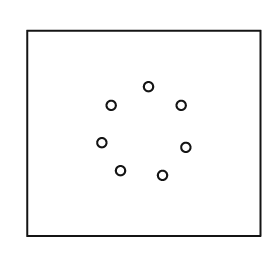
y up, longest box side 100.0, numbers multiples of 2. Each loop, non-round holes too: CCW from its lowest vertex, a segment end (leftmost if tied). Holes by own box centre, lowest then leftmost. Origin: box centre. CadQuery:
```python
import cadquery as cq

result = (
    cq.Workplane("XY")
    .moveTo(-50.0, -44.0)
    .lineTo(50.0, -44.0)
    .lineTo(50.0, 44.0)
    .lineTo(-50.0, 44.0)
    .close()
    .moveTo(8.0, -18.0)
    .circle(2.0)
    .moveTo(-10.0, -16.0)
    .circle(2.0)
    .moveTo(18.0, -6.0)
    .circle(2.0)
    .moveTo(-18.0, -4.0)
    .circle(2.0)
    .moveTo(-14.0, 12.0)
    .circle(2.0)
    .moveTo(16.0, 12.0)
    .circle(2.0)
    .moveTo(2.0, 20.0)
    .circle(2.0)
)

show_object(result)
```